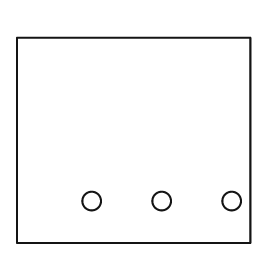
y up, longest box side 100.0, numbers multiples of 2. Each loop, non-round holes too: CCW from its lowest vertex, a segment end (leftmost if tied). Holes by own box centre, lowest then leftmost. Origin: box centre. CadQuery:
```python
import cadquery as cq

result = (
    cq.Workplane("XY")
    .moveTo(-50.0, -44.0)
    .lineTo(50.0, -44.0)
    .lineTo(50.0, 44.0)
    .lineTo(-50.0, 44.0)
    .close()
    .moveTo(-18.0, -26.0)
    .circle(4.0)
    .moveTo(12.0, -26.0)
    .circle(4.0)
    .moveTo(42.0, -26.0)
    .circle(4.0)
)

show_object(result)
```